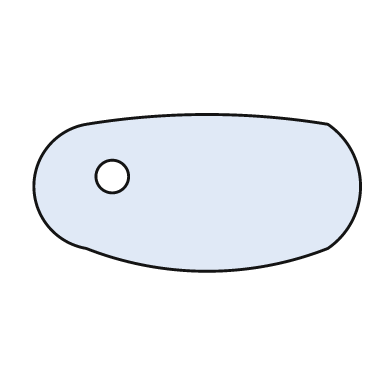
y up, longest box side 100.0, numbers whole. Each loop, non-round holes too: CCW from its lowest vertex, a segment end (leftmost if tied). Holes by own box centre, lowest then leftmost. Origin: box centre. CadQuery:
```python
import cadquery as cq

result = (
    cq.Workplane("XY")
    .moveTo(-34.0, -17.0)
    .threePointArc((3.0, -24.0), (40.0, -17.0))
    .threePointArc((50.0, 2.0), (40.0, 21.0))
    .threePointArc((3.0, 24.0), (-34.0, 21.0))
    .threePointArc((-50.0, 2.0), (-34.0, -17.0))
    .close()
    .moveTo(-26.0, 5.0)
    .circle(5.0)
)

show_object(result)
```